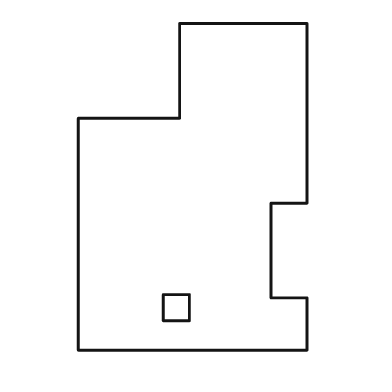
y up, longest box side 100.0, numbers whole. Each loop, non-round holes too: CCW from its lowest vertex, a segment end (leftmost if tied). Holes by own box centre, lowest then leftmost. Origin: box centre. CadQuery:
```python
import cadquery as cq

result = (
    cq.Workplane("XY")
    .moveTo(-35.0, -50.0)
    .lineTo(35.0, -50.0)
    .lineTo(35.0, -34.0)
    .lineTo(24.0, -34.0)
    .lineTo(24.0, -5.0)
    .lineTo(35.0, -5.0)
    .lineTo(35.0, 50.0)
    .lineTo(-4.0, 50.0)
    .lineTo(-4.0, 21.0)
    .lineTo(-35.0, 21.0)
    .close()
    .moveTo(-9.0, -41.0)
    .lineTo(-1.0, -41.0)
    .lineTo(-1.0, -33.0)
    .lineTo(-9.0, -33.0)
    .close()
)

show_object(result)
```